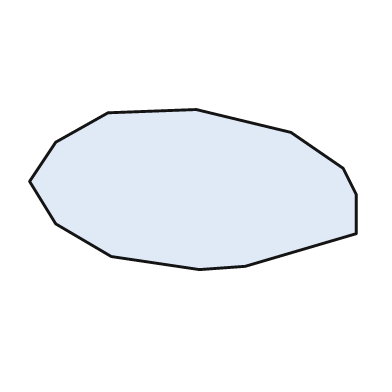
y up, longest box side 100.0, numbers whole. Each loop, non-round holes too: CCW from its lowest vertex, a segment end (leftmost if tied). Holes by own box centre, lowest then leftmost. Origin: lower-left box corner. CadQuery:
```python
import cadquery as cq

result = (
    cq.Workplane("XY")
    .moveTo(52.0, 0.0)
    .lineTo(66.0, 1.0)
    .lineTo(100.0, 11.0)
    .lineTo(100.0, 23.0)
    .lineTo(96.0, 31.0)
    .lineTo(80.0, 42.0)
    .lineTo(51.0, 49.0)
    .lineTo(24.0, 48.0)
    .lineTo(8.0, 39.0)
    .lineTo(0.0, 27.0)
    .lineTo(8.0, 14.0)
    .lineTo(25.0, 4.0)
    .close()
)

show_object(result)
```